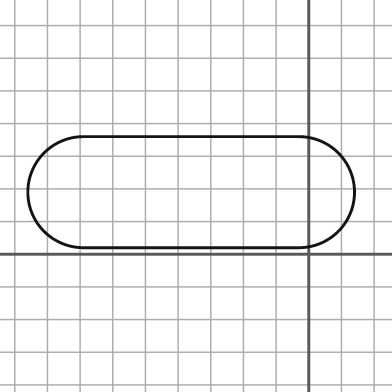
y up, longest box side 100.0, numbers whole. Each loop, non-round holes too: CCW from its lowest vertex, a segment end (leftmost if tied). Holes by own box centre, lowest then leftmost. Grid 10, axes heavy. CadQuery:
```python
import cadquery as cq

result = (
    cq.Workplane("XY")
    .moveTo(-69.0, 2.0)
    .lineTo(-3.0, 2.0)
    .threePointArc((14.0, 19.0), (-3.0, 36.0))
    .lineTo(-69.0, 36.0)
    .threePointArc((-86.0, 19.0), (-69.0, 2.0))
    .close()
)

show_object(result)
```